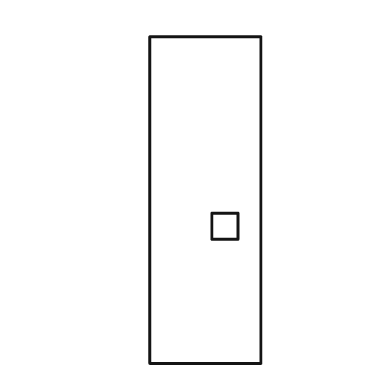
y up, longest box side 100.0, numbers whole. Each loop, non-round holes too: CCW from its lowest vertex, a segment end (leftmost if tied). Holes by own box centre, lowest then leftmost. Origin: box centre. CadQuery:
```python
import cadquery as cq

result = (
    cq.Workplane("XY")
    .moveTo(-17.0, -50.0)
    .lineTo(17.0, -50.0)
    .lineTo(17.0, 50.0)
    .lineTo(-17.0, 50.0)
    .close()
    .moveTo(2.0, -12.0)
    .lineTo(10.0, -12.0)
    .lineTo(10.0, -4.0)
    .lineTo(2.0, -4.0)
    .close()
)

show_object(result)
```